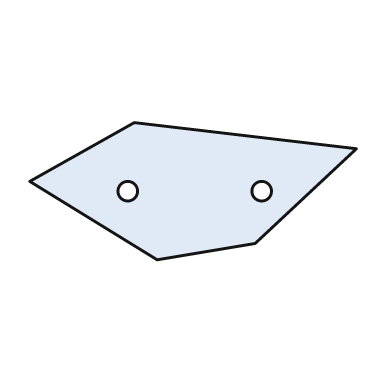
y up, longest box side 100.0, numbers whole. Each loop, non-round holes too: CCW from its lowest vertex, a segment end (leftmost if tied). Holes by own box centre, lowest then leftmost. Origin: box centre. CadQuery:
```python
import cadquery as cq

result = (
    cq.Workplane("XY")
    .moveTo(-11.0, -21.0)
    .lineTo(19.0, -16.0)
    .lineTo(50.0, 13.0)
    .lineTo(-18.0, 21.0)
    .lineTo(-50.0, 3.0)
    .close()
    .moveTo(-20.0, 0.0)
    .circle(3.0)
    .moveTo(21.0, 0.0)
    .circle(3.0)
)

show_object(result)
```